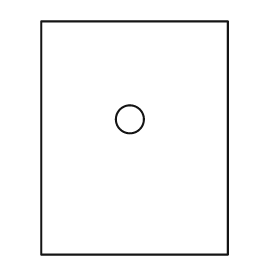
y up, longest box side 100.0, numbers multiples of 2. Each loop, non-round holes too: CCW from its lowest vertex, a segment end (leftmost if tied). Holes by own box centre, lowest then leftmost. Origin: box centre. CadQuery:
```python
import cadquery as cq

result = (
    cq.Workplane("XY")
    .moveTo(-40.0, -50.0)
    .lineTo(40.0, -50.0)
    .lineTo(40.0, 50.0)
    .lineTo(-40.0, 50.0)
    .close()
    .moveTo(-2.0, 8.0)
    .circle(6.0)
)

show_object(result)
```